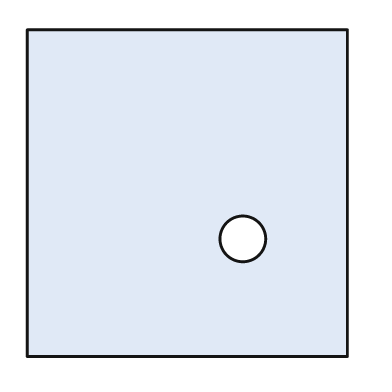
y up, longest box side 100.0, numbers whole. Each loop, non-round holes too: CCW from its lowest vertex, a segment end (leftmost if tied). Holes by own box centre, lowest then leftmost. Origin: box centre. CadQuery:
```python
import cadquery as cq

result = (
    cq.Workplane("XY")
    .moveTo(-49.0, -50.0)
    .lineTo(49.0, -50.0)
    .lineTo(49.0, 50.0)
    .lineTo(-49.0, 50.0)
    .close()
    .moveTo(17.0, -14.0)
    .circle(7.0)
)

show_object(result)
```